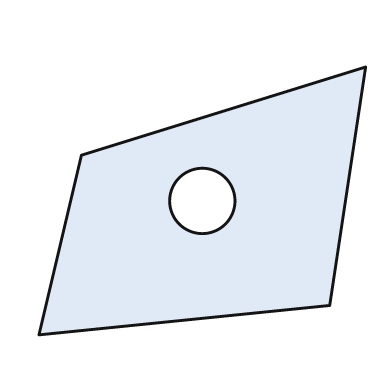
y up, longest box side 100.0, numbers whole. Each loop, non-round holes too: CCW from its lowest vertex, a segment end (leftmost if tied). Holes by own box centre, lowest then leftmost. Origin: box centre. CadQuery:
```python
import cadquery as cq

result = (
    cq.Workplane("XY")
    .moveTo(-50.0, -41.0)
    .lineTo(39.0, -32.0)
    .lineTo(50.0, 41.0)
    .lineTo(-37.0, 14.0)
    .close()
    .moveTo(0.0, 0.0)
    .circle(10.0)
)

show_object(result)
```